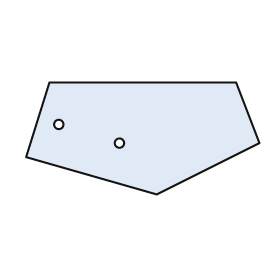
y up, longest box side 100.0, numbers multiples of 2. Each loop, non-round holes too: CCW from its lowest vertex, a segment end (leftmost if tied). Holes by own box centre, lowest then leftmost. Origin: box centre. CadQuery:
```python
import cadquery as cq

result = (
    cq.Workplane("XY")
    .moveTo(6.0, -24.0)
    .lineTo(50.0, -2.0)
    .lineTo(40.0, 24.0)
    .lineTo(-40.0, 24.0)
    .lineTo(-50.0, -8.0)
    .close()
    .moveTo(-10.0, -2.0)
    .circle(2.0)
    .moveTo(-36.0, 6.0)
    .circle(2.0)
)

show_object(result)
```